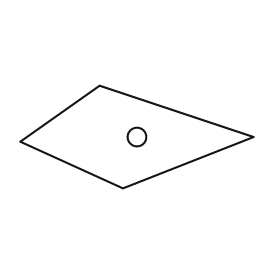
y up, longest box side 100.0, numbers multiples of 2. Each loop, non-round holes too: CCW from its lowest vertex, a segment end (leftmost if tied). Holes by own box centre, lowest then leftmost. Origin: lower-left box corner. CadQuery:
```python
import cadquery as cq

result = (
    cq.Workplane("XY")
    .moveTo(44.0, 0.0)
    .lineTo(100.0, 22.0)
    .lineTo(34.0, 44.0)
    .lineTo(0.0, 20.0)
    .close()
    .moveTo(50.0, 22.0)
    .circle(4.0)
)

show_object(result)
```